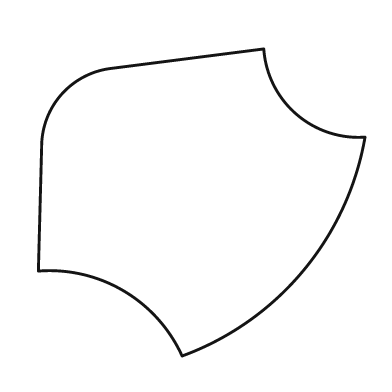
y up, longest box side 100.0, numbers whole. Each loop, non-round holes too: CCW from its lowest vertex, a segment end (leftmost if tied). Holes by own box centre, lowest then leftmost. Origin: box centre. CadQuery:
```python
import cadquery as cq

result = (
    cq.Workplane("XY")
    .moveTo(-6.0, -47.0)
    .threePointArc((31.0, -21.0), (50.0, 20.0))
    .threePointArc((29.0, 27.0), (19.0, 47.0))
    .lineTo(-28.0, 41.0)
    .threePointArc((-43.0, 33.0), (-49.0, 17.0))
    .lineTo(-50.0, -21.0)
    .threePointArc((-24.0, -27.0), (-6.0, -47.0))
    .close()
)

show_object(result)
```